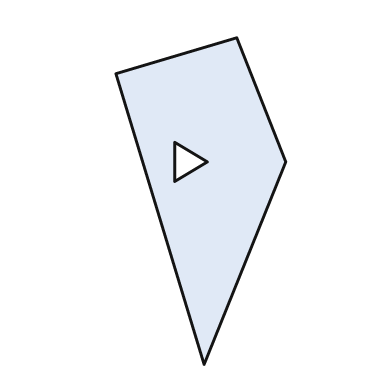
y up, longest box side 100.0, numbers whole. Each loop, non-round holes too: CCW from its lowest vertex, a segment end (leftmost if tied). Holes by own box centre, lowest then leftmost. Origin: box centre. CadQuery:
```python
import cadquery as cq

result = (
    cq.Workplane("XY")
    .moveTo(1.0, -50.0)
    .lineTo(26.0, 12.0)
    .lineTo(11.0, 50.0)
    .lineTo(-26.0, 39.0)
    .close()
    .moveTo(-8.0, 6.0)
    .lineTo(2.0, 12.0)
    .lineTo(-8.0, 18.0)
    .close()
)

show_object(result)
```